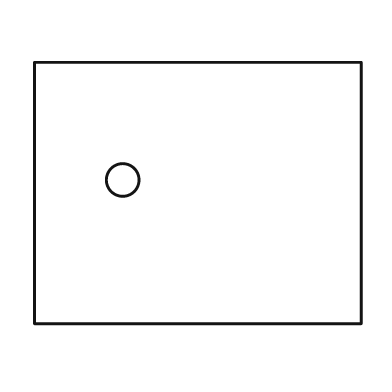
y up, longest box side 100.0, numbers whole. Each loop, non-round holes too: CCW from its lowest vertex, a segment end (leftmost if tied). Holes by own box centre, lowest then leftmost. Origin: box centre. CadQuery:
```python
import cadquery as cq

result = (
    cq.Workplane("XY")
    .moveTo(-50.0, -40.0)
    .lineTo(50.0, -40.0)
    .lineTo(50.0, 40.0)
    .lineTo(-50.0, 40.0)
    .close()
    .moveTo(-23.0, 4.0)
    .circle(5.0)
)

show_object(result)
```